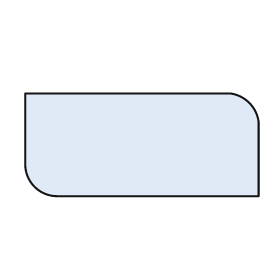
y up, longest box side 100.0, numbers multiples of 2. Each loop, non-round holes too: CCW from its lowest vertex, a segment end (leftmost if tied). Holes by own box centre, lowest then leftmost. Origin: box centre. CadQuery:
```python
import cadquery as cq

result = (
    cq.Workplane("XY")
    .moveTo(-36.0, -22.0)
    .lineTo(50.0, -22.0)
    .lineTo(50.0, 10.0)
    .threePointArc((46.0, 18.0), (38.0, 22.0))
    .lineTo(-50.0, 22.0)
    .lineTo(-50.0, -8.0)
    .threePointArc((-46.0, -18.0), (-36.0, -22.0))
    .close()
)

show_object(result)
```